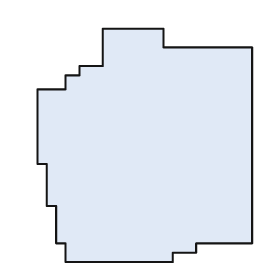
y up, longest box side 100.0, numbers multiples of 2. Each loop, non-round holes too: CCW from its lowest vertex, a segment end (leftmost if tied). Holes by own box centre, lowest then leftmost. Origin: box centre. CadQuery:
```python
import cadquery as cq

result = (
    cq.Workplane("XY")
    .moveTo(-34.0, -50.0)
    .lineTo(12.0, -50.0)
    .lineTo(12.0, -46.0)
    .lineTo(22.0, -46.0)
    .lineTo(22.0, -42.0)
    .lineTo(46.0, -42.0)
    .lineTo(46.0, 42.0)
    .lineTo(8.0, 42.0)
    .lineTo(8.0, 50.0)
    .lineTo(-18.0, 50.0)
    .lineTo(-18.0, 34.0)
    .lineTo(-28.0, 34.0)
    .lineTo(-28.0, 30.0)
    .lineTo(-34.0, 30.0)
    .lineTo(-34.0, 24.0)
    .lineTo(-46.0, 24.0)
    .lineTo(-46.0, -8.0)
    .lineTo(-42.0, -8.0)
    .lineTo(-42.0, -26.0)
    .lineTo(-38.0, -26.0)
    .lineTo(-38.0, -42.0)
    .lineTo(-34.0, -42.0)
    .close()
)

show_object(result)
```